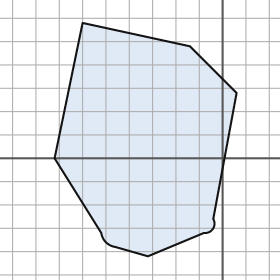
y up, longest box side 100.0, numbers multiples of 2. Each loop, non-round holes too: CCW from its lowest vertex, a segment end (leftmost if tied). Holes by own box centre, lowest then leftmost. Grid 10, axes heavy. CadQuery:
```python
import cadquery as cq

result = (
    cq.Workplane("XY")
    .moveTo(-32.0, -42.0)
    .lineTo(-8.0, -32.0)
    .threePointArc((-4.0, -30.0), (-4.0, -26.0))
    .lineTo(6.0, 28.0)
    .lineTo(-14.0, 48.0)
    .lineTo(-60.0, 58.0)
    .lineTo(-72.0, 0.0)
    .lineTo(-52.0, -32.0)
    .threePointArc((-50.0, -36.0), (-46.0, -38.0))
    .close()
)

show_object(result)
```